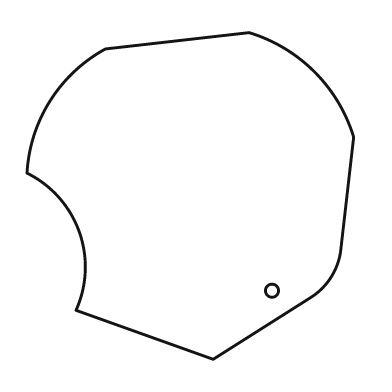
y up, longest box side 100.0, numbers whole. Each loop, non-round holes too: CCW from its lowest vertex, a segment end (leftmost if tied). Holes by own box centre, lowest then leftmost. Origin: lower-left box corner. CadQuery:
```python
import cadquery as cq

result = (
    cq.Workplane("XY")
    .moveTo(57.0, 0.0)
    .lineTo(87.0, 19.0)
    .threePointArc((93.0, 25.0), (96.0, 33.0))
    .lineTo(100.0, 68.0)
    .threePointArc((88.0, 88.0), (68.0, 100.0))
    .lineTo(24.0, 95.0)
    .threePointArc((7.0, 79.0), (0.0, 57.0))
    .threePointArc((16.0, 39.0), (15.0, 15.0))
    .close()
    .moveTo(75.0, 21.0)
    .circle(2.0)
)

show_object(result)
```